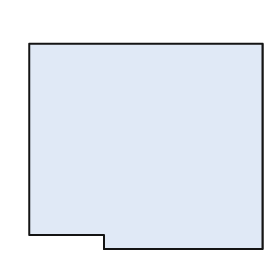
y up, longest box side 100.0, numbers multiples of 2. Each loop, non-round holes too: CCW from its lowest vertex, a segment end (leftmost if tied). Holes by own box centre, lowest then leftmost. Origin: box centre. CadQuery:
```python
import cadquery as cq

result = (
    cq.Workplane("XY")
    .moveTo(-18.0, -44.0)
    .lineTo(50.0, -44.0)
    .lineTo(50.0, 44.0)
    .lineTo(-50.0, 44.0)
    .lineTo(-50.0, -38.0)
    .lineTo(-18.0, -38.0)
    .close()
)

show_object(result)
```